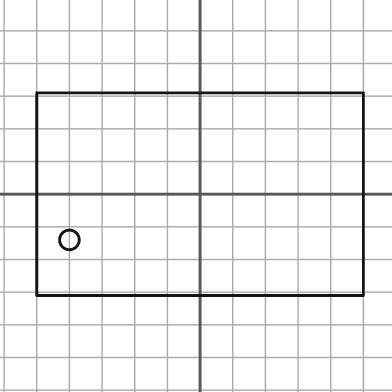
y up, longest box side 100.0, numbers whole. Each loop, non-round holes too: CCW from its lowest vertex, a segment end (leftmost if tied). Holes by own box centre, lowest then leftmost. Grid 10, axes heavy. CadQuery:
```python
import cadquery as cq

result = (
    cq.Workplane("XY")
    .moveTo(-50.0, -31.0)
    .lineTo(50.0, -31.0)
    .lineTo(50.0, 31.0)
    .lineTo(-50.0, 31.0)
    .close()
    .moveTo(-40.0, -14.0)
    .circle(3.0)
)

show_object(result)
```